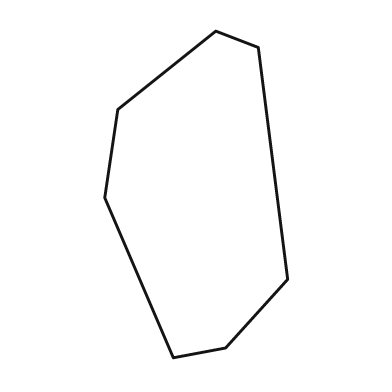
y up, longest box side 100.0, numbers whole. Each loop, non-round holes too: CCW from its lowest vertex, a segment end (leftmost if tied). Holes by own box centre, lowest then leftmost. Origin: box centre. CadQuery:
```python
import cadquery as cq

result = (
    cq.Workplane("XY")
    .moveTo(-7.0, -50.0)
    .lineTo(9.0, -47.0)
    .lineTo(28.0, -26.0)
    .lineTo(19.0, 45.0)
    .lineTo(6.0, 50.0)
    .lineTo(-24.0, 26.0)
    .lineTo(-28.0, -1.0)
    .close()
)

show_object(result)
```